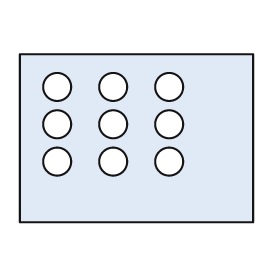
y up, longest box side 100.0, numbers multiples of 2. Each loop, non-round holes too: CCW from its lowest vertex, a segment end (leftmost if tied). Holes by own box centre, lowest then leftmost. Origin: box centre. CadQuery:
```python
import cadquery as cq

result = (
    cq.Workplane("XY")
    .moveTo(-50.0, -36.0)
    .lineTo(50.0, -36.0)
    .lineTo(50.0, 36.0)
    .lineTo(-50.0, 36.0)
    .close()
    .moveTo(-34.0, -10.0)
    .circle(6.0)
    .moveTo(-10.0, -10.0)
    .circle(6.0)
    .moveTo(14.0, -10.0)
    .circle(6.0)
    .moveTo(-34.0, 6.0)
    .circle(6.0)
    .moveTo(-10.0, 6.0)
    .circle(6.0)
    .moveTo(14.0, 6.0)
    .circle(6.0)
    .moveTo(-34.0, 22.0)
    .circle(6.0)
    .moveTo(-10.0, 22.0)
    .circle(6.0)
    .moveTo(14.0, 22.0)
    .circle(6.0)
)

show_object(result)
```